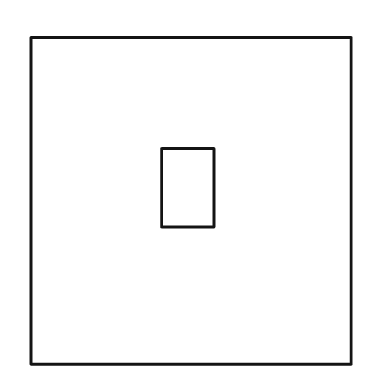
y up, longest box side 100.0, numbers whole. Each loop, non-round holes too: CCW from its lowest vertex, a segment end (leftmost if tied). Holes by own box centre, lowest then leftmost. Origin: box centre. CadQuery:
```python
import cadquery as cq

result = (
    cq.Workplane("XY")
    .moveTo(-49.0, -50.0)
    .lineTo(49.0, -50.0)
    .lineTo(49.0, 50.0)
    .lineTo(-49.0, 50.0)
    .close()
    .moveTo(-9.0, -8.0)
    .lineTo(7.0, -8.0)
    .lineTo(7.0, 16.0)
    .lineTo(-9.0, 16.0)
    .close()
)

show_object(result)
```